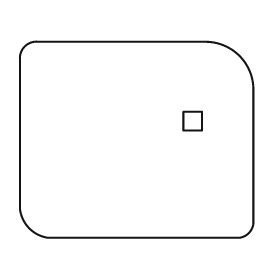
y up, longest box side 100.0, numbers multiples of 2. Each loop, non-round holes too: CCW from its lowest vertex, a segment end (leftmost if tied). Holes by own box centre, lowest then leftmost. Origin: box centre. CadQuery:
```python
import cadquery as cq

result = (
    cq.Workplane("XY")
    .moveTo(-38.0, -42.0)
    .lineTo(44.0, -42.0)
    .threePointArc((48.0, -40.0), (50.0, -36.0))
    .lineTo(50.0, 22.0)
    .threePointArc((44.0, 36.0), (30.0, 42.0))
    .lineTo(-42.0, 42.0)
    .threePointArc((-48.0, 40.0), (-50.0, 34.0))
    .lineTo(-50.0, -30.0)
    .threePointArc((-46.0, -38.0), (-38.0, -42.0))
    .close()
    .moveTo(20.0, 4.0)
    .lineTo(28.0, 4.0)
    .lineTo(28.0, 12.0)
    .lineTo(20.0, 12.0)
    .close()
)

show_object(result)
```